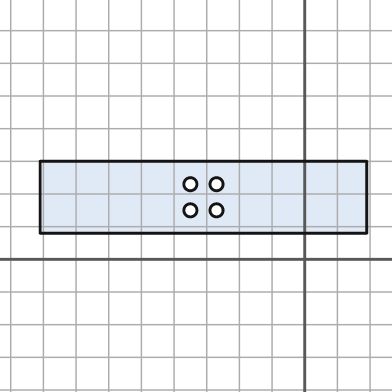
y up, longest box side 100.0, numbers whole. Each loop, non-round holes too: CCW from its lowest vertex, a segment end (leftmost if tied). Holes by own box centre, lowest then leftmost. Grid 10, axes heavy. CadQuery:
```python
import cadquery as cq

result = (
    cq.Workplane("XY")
    .moveTo(-81.0, 8.0)
    .lineTo(19.0, 8.0)
    .lineTo(19.0, 30.0)
    .lineTo(-81.0, 30.0)
    .close()
    .moveTo(-35.0, 15.0)
    .circle(2.0)
    .moveTo(-27.0, 15.0)
    .circle(2.0)
    .moveTo(-35.0, 23.0)
    .circle(2.0)
    .moveTo(-27.0, 23.0)
    .circle(2.0)
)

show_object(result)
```